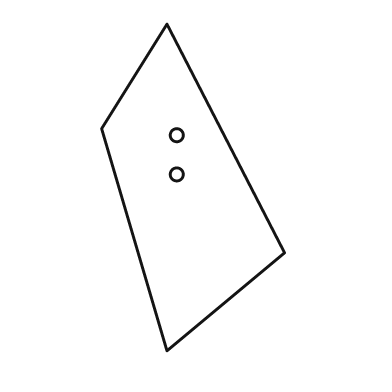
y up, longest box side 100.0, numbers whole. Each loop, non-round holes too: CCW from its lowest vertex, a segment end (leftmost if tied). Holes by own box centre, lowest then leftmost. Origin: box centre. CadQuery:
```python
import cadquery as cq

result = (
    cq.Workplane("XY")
    .moveTo(-8.0, -50.0)
    .lineTo(28.0, -20.0)
    .lineTo(-8.0, 50.0)
    .lineTo(-28.0, 18.0)
    .close()
    .moveTo(-5.0, 4.0)
    .circle(2.0)
    .moveTo(-5.0, 16.0)
    .circle(2.0)
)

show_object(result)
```